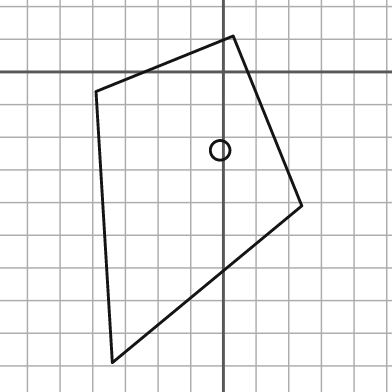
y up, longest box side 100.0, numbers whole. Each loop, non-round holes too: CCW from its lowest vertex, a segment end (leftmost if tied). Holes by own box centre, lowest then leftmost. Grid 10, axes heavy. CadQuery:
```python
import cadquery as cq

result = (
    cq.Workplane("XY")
    .moveTo(-34.0, -89.0)
    .lineTo(24.0, -41.0)
    .lineTo(3.0, 11.0)
    .lineTo(-39.0, -6.0)
    .close()
    .moveTo(-1.0, -24.0)
    .circle(3.0)
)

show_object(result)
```